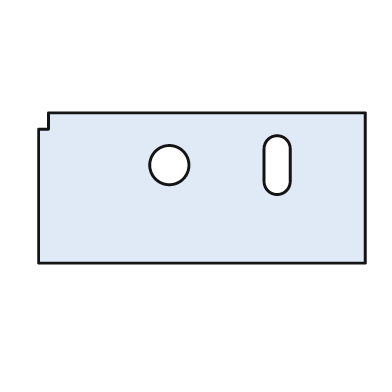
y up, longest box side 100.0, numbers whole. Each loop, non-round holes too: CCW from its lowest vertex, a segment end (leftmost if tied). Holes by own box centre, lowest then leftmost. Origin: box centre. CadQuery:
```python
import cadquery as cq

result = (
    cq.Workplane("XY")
    .moveTo(-50.0, -23.0)
    .lineTo(50.0, -23.0)
    .lineTo(50.0, 23.0)
    .lineTo(-47.0, 23.0)
    .lineTo(-47.0, 18.0)
    .lineTo(-50.0, 18.0)
    .close()
    .moveTo(-10.0, 7.0)
    .circle(6.0)
    .moveTo(19.0, 2.0)
    .threePointArc((23.0, -2.0), (27.0, 2.0))
    .lineTo(27.0, 12.0)
    .threePointArc((23.0, 16.0), (19.0, 12.0))
    .close()
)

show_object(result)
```